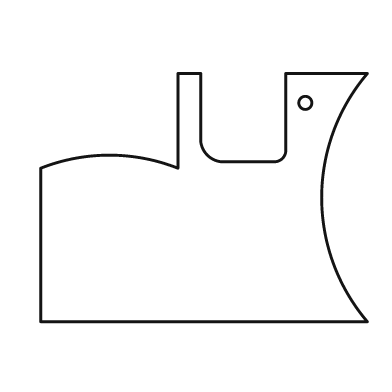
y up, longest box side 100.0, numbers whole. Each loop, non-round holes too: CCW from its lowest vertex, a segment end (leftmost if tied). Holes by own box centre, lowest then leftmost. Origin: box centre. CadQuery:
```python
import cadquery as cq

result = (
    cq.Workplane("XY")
    .moveTo(-50.0, -38.0)
    .lineTo(50.0, -38.0)
    .threePointArc((36.0, 0.0), (50.0, 38.0))
    .lineTo(25.0, 38.0)
    .lineTo(25.0, 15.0)
    .threePointArc((24.0, 12.0), (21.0, 11.0))
    .lineTo(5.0, 11.0)
    .threePointArc((1.0, 13.0), (-1.0, 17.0))
    .lineTo(-1.0, 38.0)
    .lineTo(-8.0, 38.0)
    .lineTo(-8.0, 9.0)
    .threePointArc((-29.0, 13.0), (-50.0, 9.0))
    .close()
    .moveTo(31.0, 29.0)
    .circle(2.0)
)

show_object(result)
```